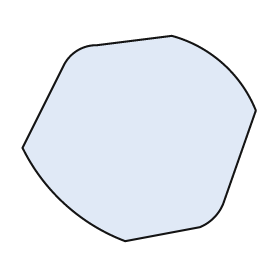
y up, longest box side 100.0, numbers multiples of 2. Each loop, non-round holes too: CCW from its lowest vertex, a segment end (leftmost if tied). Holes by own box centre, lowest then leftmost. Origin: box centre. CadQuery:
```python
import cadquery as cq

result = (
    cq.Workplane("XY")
    .moveTo(-6.0, -44.0)
    .lineTo(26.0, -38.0)
    .threePointArc((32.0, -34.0), (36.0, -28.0))
    .lineTo(50.0, 12.0)
    .threePointArc((36.0, 32.0), (14.0, 44.0))
    .lineTo(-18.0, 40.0)
    .threePointArc((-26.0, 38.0), (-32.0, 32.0))
    .lineTo(-50.0, -4.0)
    .threePointArc((-32.0, -28.0), (-6.0, -44.0))
    .close()
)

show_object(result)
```